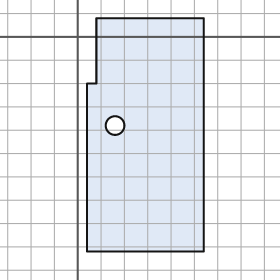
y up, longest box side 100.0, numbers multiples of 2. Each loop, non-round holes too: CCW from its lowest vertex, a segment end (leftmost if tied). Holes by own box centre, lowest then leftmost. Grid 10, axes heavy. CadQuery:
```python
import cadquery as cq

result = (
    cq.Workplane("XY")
    .moveTo(4.0, -92.0)
    .lineTo(54.0, -92.0)
    .lineTo(54.0, 8.0)
    .lineTo(8.0, 8.0)
    .lineTo(8.0, -20.0)
    .lineTo(4.0, -20.0)
    .close()
    .moveTo(16.0, -38.0)
    .circle(4.0)
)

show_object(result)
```